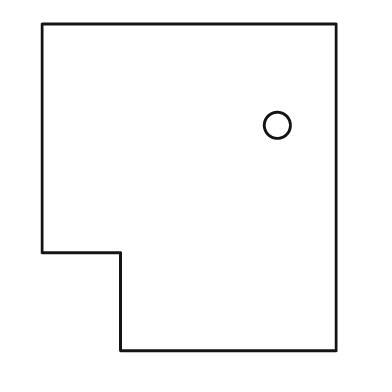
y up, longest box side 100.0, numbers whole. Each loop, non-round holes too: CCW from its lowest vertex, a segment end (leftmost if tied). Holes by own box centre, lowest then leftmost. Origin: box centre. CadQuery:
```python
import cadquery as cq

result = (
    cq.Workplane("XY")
    .moveTo(-21.0, -50.0)
    .lineTo(45.0, -50.0)
    .lineTo(45.0, 50.0)
    .lineTo(-45.0, 50.0)
    .lineTo(-45.0, -20.0)
    .lineTo(-21.0, -20.0)
    .close()
    .moveTo(27.0, 19.0)
    .circle(4.0)
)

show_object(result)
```